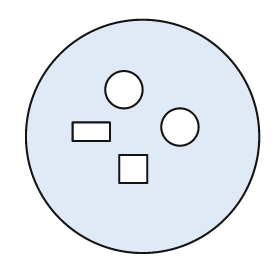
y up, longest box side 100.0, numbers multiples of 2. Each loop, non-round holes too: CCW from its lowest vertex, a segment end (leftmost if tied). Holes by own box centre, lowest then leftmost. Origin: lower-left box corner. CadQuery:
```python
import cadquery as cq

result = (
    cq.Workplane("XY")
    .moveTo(50.0, 50.0)
    .circle(50.0)
    .moveTo(40.0, 30.0)
    .lineTo(52.0, 30.0)
    .lineTo(52.0, 42.0)
    .lineTo(40.0, 42.0)
    .close()
    .moveTo(20.0, 48.0)
    .lineTo(36.0, 48.0)
    .lineTo(36.0, 56.0)
    .lineTo(20.0, 56.0)
    .close()
    .moveTo(66.0, 54.0)
    .circle(8.0)
    .moveTo(42.0, 70.0)
    .circle(8.0)
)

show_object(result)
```